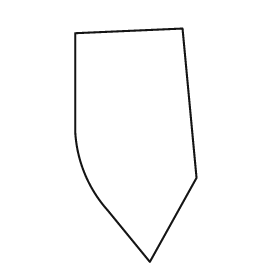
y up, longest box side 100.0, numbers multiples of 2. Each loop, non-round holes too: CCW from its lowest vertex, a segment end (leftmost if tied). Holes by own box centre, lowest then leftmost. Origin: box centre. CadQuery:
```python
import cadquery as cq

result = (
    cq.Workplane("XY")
    .moveTo(6.0, -50.0)
    .lineTo(26.0, -14.0)
    .lineTo(20.0, 50.0)
    .lineTo(-26.0, 48.0)
    .lineTo(-26.0, 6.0)
    .threePointArc((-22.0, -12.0), (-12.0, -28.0))
    .close()
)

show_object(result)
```